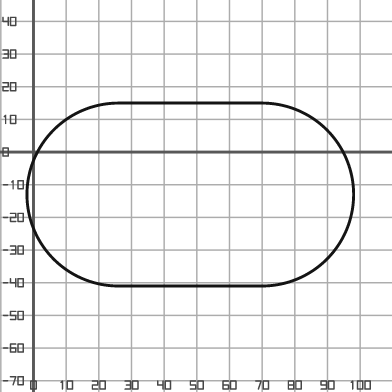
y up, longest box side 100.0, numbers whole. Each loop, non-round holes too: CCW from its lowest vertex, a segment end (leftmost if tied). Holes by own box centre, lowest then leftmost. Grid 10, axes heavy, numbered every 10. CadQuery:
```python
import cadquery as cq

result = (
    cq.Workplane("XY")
    .moveTo(26.0, -41.0)
    .lineTo(70.0, -41.0)
    .threePointArc((98.0, -13.0), (70.0, 15.0))
    .lineTo(26.0, 15.0)
    .threePointArc((-2.0, -13.0), (26.0, -41.0))
    .close()
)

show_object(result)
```